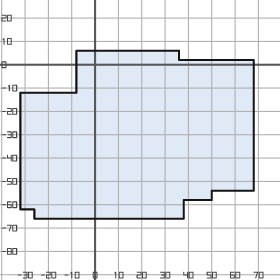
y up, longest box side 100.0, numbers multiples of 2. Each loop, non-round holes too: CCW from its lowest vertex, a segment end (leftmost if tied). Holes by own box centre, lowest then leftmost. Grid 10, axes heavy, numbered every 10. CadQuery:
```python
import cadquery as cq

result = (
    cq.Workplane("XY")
    .moveTo(-26.0, -66.0)
    .lineTo(38.0, -66.0)
    .lineTo(38.0, -58.0)
    .lineTo(50.0, -58.0)
    .lineTo(50.0, -54.0)
    .lineTo(68.0, -54.0)
    .lineTo(68.0, 2.0)
    .lineTo(36.0, 2.0)
    .lineTo(36.0, 6.0)
    .lineTo(-8.0, 6.0)
    .lineTo(-8.0, -12.0)
    .lineTo(-32.0, -12.0)
    .lineTo(-32.0, -62.0)
    .lineTo(-26.0, -62.0)
    .close()
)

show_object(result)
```